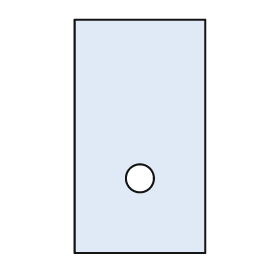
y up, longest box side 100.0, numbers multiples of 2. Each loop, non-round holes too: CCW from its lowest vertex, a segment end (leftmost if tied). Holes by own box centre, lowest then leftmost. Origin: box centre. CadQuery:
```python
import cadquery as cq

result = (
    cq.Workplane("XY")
    .moveTo(-28.0, -50.0)
    .lineTo(28.0, -50.0)
    .lineTo(28.0, 50.0)
    .lineTo(-28.0, 50.0)
    .close()
    .moveTo(0.0, -18.0)
    .circle(6.0)
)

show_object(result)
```